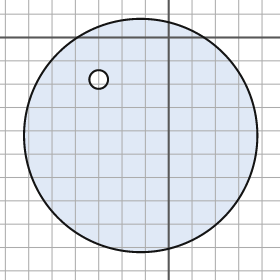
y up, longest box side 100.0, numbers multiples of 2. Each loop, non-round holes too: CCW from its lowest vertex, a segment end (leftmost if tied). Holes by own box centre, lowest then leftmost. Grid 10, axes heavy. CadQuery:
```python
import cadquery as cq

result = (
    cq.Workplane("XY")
    .moveTo(-12.0, -42.0)
    .circle(50.0)
    .moveTo(-30.0, -18.0)
    .circle(4.0)
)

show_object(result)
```